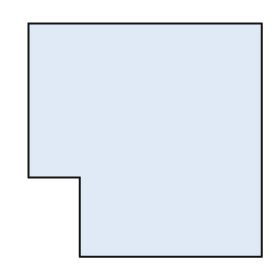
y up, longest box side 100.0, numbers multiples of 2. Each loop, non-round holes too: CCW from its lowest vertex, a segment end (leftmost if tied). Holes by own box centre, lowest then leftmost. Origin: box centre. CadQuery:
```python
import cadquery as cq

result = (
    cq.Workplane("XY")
    .moveTo(-28.0, -50.0)
    .lineTo(50.0, -50.0)
    .lineTo(50.0, 50.0)
    .lineTo(-50.0, 50.0)
    .lineTo(-50.0, -16.0)
    .lineTo(-28.0, -16.0)
    .close()
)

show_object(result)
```